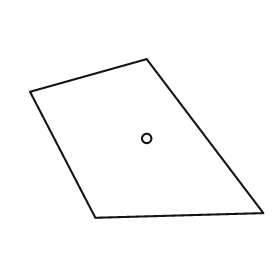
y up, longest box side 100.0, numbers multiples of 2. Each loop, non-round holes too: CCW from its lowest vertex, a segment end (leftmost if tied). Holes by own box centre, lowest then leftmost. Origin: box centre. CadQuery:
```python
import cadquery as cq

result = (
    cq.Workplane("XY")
    .moveTo(-22.0, -34.0)
    .lineTo(50.0, -32.0)
    .lineTo(0.0, 34.0)
    .lineTo(-50.0, 20.0)
    .close()
    .moveTo(0.0, 0.0)
    .circle(2.0)
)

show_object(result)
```